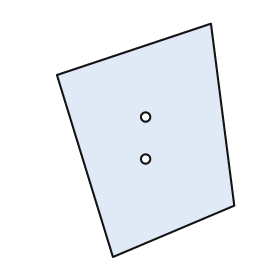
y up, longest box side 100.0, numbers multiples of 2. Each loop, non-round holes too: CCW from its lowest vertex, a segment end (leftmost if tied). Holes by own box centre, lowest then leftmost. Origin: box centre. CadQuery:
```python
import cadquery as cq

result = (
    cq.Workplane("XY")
    .moveTo(-14.0, -50.0)
    .lineTo(38.0, -28.0)
    .lineTo(28.0, 50.0)
    .lineTo(-38.0, 28.0)
    .close()
    .moveTo(0.0, -8.0)
    .circle(2.0)
    .moveTo(0.0, 10.0)
    .circle(2.0)
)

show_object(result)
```